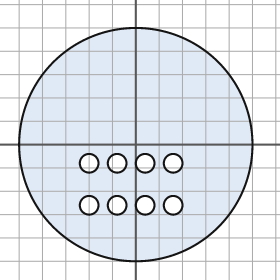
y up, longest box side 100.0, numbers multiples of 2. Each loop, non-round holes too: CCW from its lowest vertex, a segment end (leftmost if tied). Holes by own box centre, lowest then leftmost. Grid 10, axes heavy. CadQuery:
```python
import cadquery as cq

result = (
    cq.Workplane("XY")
    .moveTo(0.0, 0.0)
    .circle(50.0)
    .moveTo(-20.0, -26.0)
    .circle(4.0)
    .moveTo(-8.0, -26.0)
    .circle(4.0)
    .moveTo(4.0, -26.0)
    .circle(4.0)
    .moveTo(16.0, -26.0)
    .circle(4.0)
    .moveTo(-20.0, -8.0)
    .circle(4.0)
    .moveTo(-8.0, -8.0)
    .circle(4.0)
    .moveTo(4.0, -8.0)
    .circle(4.0)
    .moveTo(16.0, -8.0)
    .circle(4.0)
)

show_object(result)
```